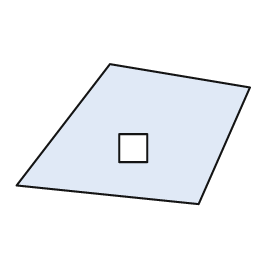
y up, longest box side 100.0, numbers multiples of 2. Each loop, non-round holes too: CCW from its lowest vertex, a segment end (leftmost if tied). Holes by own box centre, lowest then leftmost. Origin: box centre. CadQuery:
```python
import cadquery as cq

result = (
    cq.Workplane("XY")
    .moveTo(28.0, -30.0)
    .lineTo(50.0, 20.0)
    .lineTo(-10.0, 30.0)
    .lineTo(-50.0, -22.0)
    .close()
    .moveTo(-6.0, -12.0)
    .lineTo(6.0, -12.0)
    .lineTo(6.0, 0.0)
    .lineTo(-6.0, 0.0)
    .close()
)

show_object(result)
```